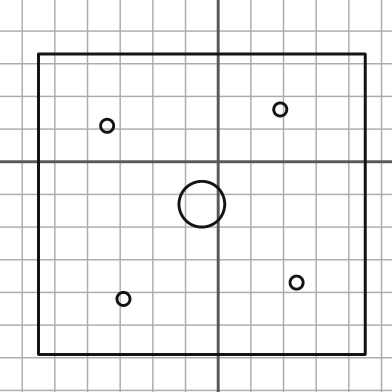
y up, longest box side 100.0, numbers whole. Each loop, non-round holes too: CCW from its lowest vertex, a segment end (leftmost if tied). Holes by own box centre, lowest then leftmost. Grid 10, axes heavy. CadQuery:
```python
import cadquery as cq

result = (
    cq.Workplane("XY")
    .moveTo(-55.0, -59.0)
    .lineTo(45.0, -59.0)
    .lineTo(45.0, 33.0)
    .lineTo(-55.0, 33.0)
    .close()
    .moveTo(-29.0, -42.0)
    .circle(2.0)
    .moveTo(24.0, -37.0)
    .circle(2.0)
    .moveTo(-5.0, -13.0)
    .circle(7.0)
    .moveTo(-34.0, 11.0)
    .circle(2.0)
    .moveTo(19.0, 16.0)
    .circle(2.0)
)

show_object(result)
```